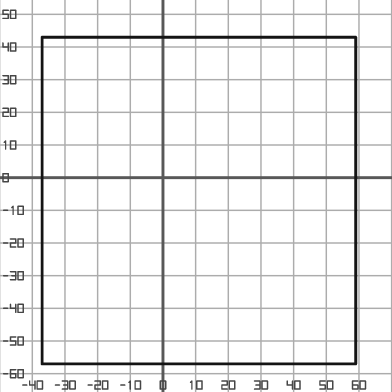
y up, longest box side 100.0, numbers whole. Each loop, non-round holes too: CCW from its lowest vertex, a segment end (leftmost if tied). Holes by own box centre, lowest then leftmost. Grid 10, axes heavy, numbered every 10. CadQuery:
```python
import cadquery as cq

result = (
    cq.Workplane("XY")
    .moveTo(-37.0, -57.0)
    .lineTo(59.0, -57.0)
    .lineTo(59.0, 43.0)
    .lineTo(-37.0, 43.0)
    .close()
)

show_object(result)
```